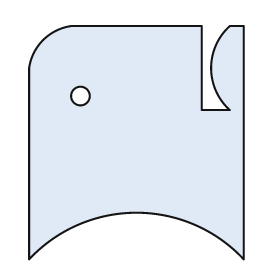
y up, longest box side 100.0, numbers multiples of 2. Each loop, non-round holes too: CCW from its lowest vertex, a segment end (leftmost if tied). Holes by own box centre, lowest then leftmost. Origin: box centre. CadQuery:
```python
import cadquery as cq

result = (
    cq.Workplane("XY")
    .moveTo(-46.0, -50.0)
    .threePointArc((0.0, -30.0), (46.0, -50.0))
    .lineTo(46.0, 50.0)
    .lineTo(40.0, 50.0)
    .threePointArc((32.0, 32.0), (40.0, 14.0))
    .lineTo(28.0, 14.0)
    .lineTo(28.0, 50.0)
    .lineTo(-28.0, 50.0)
    .threePointArc((-40.0, 44.0), (-46.0, 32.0))
    .close()
    .moveTo(-24.0, 20.0)
    .circle(4.0)
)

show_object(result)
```